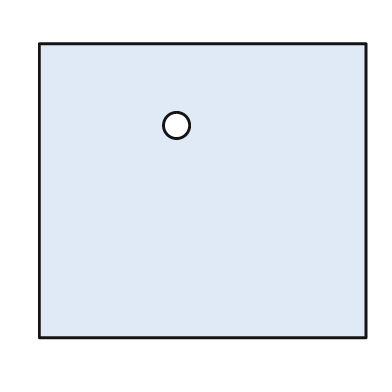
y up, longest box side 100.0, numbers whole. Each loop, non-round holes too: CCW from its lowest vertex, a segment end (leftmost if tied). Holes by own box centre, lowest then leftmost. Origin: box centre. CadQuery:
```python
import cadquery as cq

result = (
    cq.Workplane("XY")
    .moveTo(-50.0, -45.0)
    .lineTo(50.0, -45.0)
    .lineTo(50.0, 45.0)
    .lineTo(-50.0, 45.0)
    .close()
    .moveTo(-8.0, 20.0)
    .circle(4.0)
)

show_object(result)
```